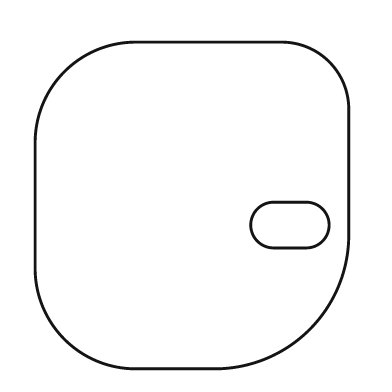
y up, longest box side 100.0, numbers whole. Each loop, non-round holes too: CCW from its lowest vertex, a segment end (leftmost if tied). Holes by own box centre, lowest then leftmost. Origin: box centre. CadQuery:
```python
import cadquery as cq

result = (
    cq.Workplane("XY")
    .moveTo(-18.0, -50.0)
    .lineTo(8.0, -50.0)
    .threePointArc((36.0, -38.0), (48.0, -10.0))
    .lineTo(48.0, 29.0)
    .threePointArc((42.0, 44.0), (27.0, 50.0))
    .lineTo(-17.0, 50.0)
    .threePointArc((-39.0, 41.0), (-48.0, 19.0))
    .lineTo(-48.0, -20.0)
    .threePointArc((-39.0, -41.0), (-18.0, -50.0))
    .close()
    .moveTo(25.0, -13.0)
    .lineTo(35.0, -13.0)
    .threePointArc((42.0, -6.0), (35.0, 1.0))
    .lineTo(25.0, 1.0)
    .threePointArc((18.0, -6.0), (25.0, -13.0))
    .close()
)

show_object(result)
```